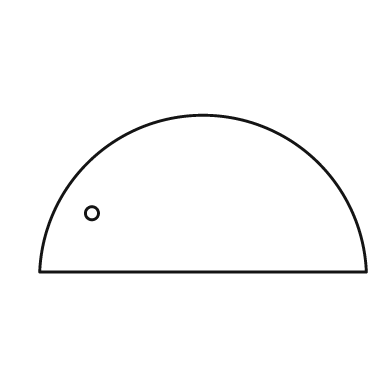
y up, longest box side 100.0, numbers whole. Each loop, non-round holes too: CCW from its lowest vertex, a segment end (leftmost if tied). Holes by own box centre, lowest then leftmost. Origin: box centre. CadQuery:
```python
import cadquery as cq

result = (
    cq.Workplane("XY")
    .moveTo(-50.0, -24.0)
    .lineTo(50.0, -24.0)
    .threePointArc((0.0, 24.0), (-50.0, -24.0))
    .close()
    .moveTo(-34.0, -6.0)
    .circle(2.0)
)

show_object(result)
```